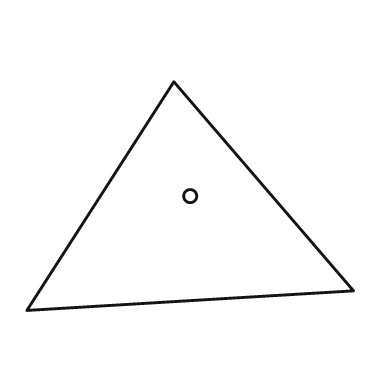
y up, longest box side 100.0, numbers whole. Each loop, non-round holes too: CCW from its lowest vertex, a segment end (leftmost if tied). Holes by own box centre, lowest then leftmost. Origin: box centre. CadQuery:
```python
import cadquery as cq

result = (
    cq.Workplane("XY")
    .moveTo(-50.0, -35.0)
    .lineTo(50.0, -29.0)
    .lineTo(-5.0, 35.0)
    .close()
    .moveTo(0.0, 0.0)
    .circle(2.0)
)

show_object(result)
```